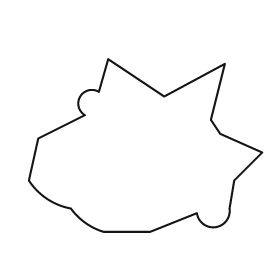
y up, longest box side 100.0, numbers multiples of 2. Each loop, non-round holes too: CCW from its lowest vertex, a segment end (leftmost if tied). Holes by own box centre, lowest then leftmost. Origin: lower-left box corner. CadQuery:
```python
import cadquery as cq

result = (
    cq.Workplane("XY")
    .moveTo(32.0, 0.0)
    .lineTo(52.0, 0.0)
    .lineTo(72.0, 8.0)
    .threePointArc((80.0, 2.0), (86.0, 10.0))
    .lineTo(88.0, 22.0)
    .lineTo(100.0, 34.0)
    .lineTo(82.0, 42.0)
    .lineTo(78.0, 48.0)
    .lineTo(84.0, 72.0)
    .lineTo(58.0, 58.0)
    .lineTo(34.0, 74.0)
    .lineTo(30.0, 60.0)
    .threePointArc((22.0, 58.0), (24.0, 50.0))
    .lineTo(4.0, 40.0)
    .lineTo(0.0, 22.0)
    .threePointArc((8.0, 14.0), (18.0, 10.0))
    .threePointArc((24.0, 4.0), (32.0, 0.0))
    .close()
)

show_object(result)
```